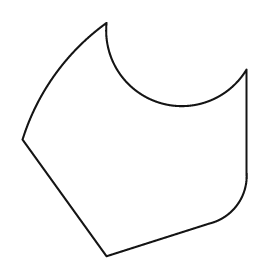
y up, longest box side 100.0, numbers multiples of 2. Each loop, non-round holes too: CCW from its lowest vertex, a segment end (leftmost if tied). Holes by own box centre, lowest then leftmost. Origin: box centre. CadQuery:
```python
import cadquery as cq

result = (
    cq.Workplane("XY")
    .moveTo(-12.0, -50.0)
    .lineTo(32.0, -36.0)
    .threePointArc((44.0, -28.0), (48.0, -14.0))
    .lineTo(48.0, 30.0)
    .threePointArc((10.0, 16.0), (-12.0, 50.0))
    .threePointArc((-34.0, 28.0), (-48.0, 0.0))
    .close()
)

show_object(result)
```